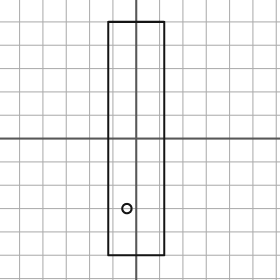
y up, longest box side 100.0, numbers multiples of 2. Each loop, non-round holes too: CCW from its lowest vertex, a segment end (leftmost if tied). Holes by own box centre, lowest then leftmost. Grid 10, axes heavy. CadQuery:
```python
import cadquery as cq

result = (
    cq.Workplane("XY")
    .moveTo(-12.0, -50.0)
    .lineTo(12.0, -50.0)
    .lineTo(12.0, 50.0)
    .lineTo(-12.0, 50.0)
    .close()
    .moveTo(-4.0, -30.0)
    .circle(2.0)
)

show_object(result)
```